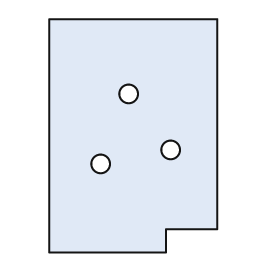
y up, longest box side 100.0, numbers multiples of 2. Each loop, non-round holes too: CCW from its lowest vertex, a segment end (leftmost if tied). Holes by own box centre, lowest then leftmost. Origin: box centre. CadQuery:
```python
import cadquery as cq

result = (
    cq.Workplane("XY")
    .moveTo(-36.0, -50.0)
    .lineTo(14.0, -50.0)
    .lineTo(14.0, -40.0)
    .lineTo(36.0, -40.0)
    .lineTo(36.0, 50.0)
    .lineTo(-36.0, 50.0)
    .close()
    .moveTo(-14.0, -12.0)
    .circle(4.0)
    .moveTo(16.0, -6.0)
    .circle(4.0)
    .moveTo(-2.0, 18.0)
    .circle(4.0)
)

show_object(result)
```